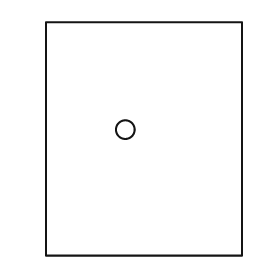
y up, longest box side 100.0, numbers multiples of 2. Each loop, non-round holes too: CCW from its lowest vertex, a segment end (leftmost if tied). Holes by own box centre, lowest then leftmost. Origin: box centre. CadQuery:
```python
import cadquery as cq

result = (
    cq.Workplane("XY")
    .moveTo(-42.0, -50.0)
    .lineTo(42.0, -50.0)
    .lineTo(42.0, 50.0)
    .lineTo(-42.0, 50.0)
    .close()
    .moveTo(-8.0, 4.0)
    .circle(4.0)
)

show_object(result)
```